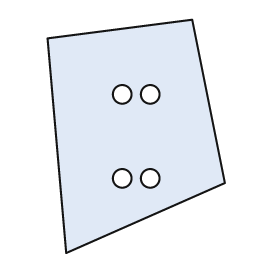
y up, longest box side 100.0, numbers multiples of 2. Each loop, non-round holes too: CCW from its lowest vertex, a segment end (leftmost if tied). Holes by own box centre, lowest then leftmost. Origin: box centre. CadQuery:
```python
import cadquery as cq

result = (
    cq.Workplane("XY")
    .moveTo(-30.0, -50.0)
    .lineTo(38.0, -20.0)
    .lineTo(24.0, 50.0)
    .lineTo(-38.0, 42.0)
    .close()
    .moveTo(-6.0, -18.0)
    .circle(4.0)
    .moveTo(6.0, -18.0)
    .circle(4.0)
    .moveTo(-6.0, 18.0)
    .circle(4.0)
    .moveTo(6.0, 18.0)
    .circle(4.0)
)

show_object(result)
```